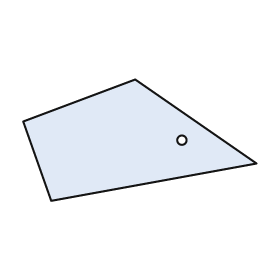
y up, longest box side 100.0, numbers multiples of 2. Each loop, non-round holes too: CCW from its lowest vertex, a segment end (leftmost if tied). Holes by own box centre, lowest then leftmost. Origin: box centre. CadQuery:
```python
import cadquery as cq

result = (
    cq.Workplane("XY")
    .moveTo(-38.0, -26.0)
    .lineTo(50.0, -10.0)
    .lineTo(-2.0, 26.0)
    .lineTo(-50.0, 8.0)
    .close()
    .moveTo(18.0, 0.0)
    .circle(2.0)
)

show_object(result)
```